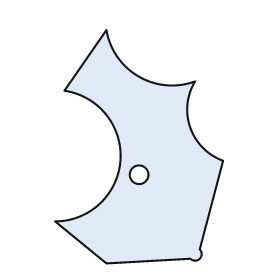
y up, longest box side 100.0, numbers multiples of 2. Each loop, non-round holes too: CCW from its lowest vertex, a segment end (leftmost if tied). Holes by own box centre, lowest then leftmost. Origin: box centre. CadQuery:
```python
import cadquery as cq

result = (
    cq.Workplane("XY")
    .moveTo(-14.0, -50.0)
    .lineTo(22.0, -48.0)
    .threePointArc((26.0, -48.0), (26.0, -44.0))
    .lineTo(36.0, -6.0)
    .threePointArc((22.0, 8.0), (24.0, 28.0))
    .threePointArc((0.0, 30.0), (-14.0, 50.0))
    .lineTo(-32.0, 24.0)
    .threePointArc((-8.0, -6.0), (-36.0, -32.0))
    .close()
    .moveTo(0.0, -12.0)
    .circle(4.0)
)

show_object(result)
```